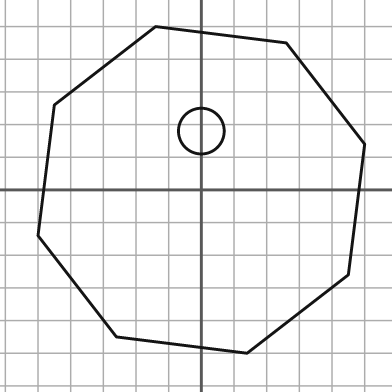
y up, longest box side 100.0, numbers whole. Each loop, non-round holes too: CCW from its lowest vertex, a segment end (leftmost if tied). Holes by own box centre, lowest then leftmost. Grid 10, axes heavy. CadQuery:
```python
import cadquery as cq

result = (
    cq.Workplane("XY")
    .moveTo(14.0, -50.0)
    .lineTo(45.0, -26.0)
    .lineTo(50.0, 14.0)
    .lineTo(26.0, 45.0)
    .lineTo(-14.0, 50.0)
    .lineTo(-45.0, 26.0)
    .lineTo(-50.0, -14.0)
    .lineTo(-26.0, -45.0)
    .close()
    .moveTo(0.0, 18.0)
    .circle(7.0)
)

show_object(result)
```